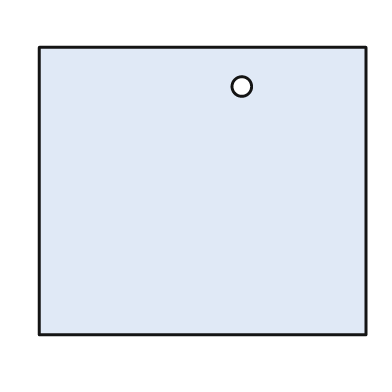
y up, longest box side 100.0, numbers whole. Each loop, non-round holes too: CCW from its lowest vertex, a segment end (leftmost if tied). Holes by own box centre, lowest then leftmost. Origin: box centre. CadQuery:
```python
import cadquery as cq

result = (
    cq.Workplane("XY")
    .moveTo(-50.0, -44.0)
    .lineTo(50.0, -44.0)
    .lineTo(50.0, 44.0)
    .lineTo(-50.0, 44.0)
    .close()
    .moveTo(12.0, 32.0)
    .circle(3.0)
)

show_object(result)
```